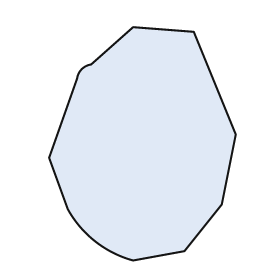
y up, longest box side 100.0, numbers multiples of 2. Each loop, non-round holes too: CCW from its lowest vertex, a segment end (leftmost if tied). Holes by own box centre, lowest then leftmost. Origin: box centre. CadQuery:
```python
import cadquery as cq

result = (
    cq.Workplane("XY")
    .moveTo(-4.0, -50.0)
    .lineTo(18.0, -46.0)
    .lineTo(34.0, -26.0)
    .lineTo(40.0, 4.0)
    .lineTo(22.0, 48.0)
    .lineTo(-4.0, 50.0)
    .lineTo(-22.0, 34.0)
    .threePointArc((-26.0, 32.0), (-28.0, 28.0))
    .lineTo(-40.0, -6.0)
    .lineTo(-32.0, -28.0)
    .threePointArc((-20.0, -42.0), (-4.0, -50.0))
    .close()
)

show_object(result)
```